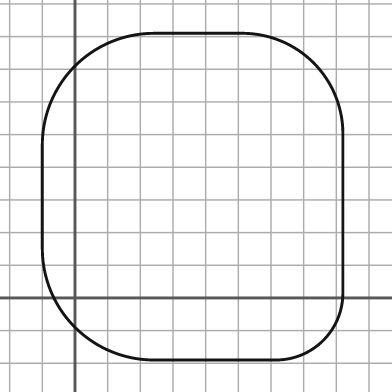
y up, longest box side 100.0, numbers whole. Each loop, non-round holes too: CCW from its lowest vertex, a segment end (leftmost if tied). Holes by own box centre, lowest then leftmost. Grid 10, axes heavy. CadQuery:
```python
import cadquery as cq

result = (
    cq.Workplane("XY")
    .moveTo(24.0, -19.0)
    .lineTo(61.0, -19.0)
    .threePointArc((76.0, -13.0), (82.0, 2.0))
    .lineTo(82.0, 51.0)
    .threePointArc((73.0, 72.0), (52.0, 81.0))
    .lineTo(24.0, 81.0)
    .threePointArc((0.0, 71.0), (-10.0, 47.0))
    .lineTo(-10.0, 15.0)
    .threePointArc((0.0, -9.0), (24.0, -19.0))
    .close()
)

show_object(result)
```